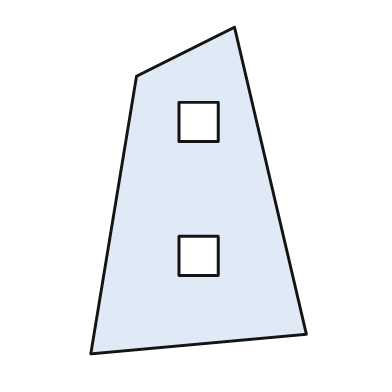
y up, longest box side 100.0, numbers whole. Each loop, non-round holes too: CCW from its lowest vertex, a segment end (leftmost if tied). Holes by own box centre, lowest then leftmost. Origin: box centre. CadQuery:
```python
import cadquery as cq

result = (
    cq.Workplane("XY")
    .moveTo(-33.0, -50.0)
    .lineTo(33.0, -44.0)
    .lineTo(11.0, 50.0)
    .lineTo(-19.0, 35.0)
    .close()
    .moveTo(-6.0, -26.0)
    .lineTo(6.0, -26.0)
    .lineTo(6.0, -14.0)
    .lineTo(-6.0, -14.0)
    .close()
    .moveTo(-6.0, 15.0)
    .lineTo(6.0, 15.0)
    .lineTo(6.0, 27.0)
    .lineTo(-6.0, 27.0)
    .close()
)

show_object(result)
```